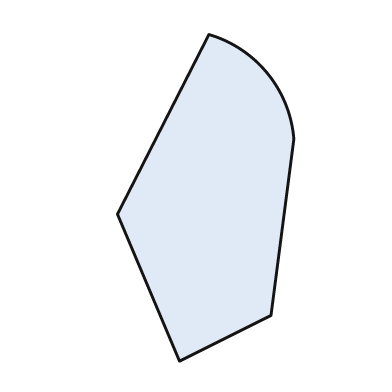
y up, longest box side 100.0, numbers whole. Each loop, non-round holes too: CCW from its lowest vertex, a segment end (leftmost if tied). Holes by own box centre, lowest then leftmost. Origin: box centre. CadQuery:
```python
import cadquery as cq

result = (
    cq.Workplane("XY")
    .moveTo(-8.0, -50.0)
    .lineTo(20.0, -36.0)
    .lineTo(27.0, 18.0)
    .threePointArc((19.0, 38.0), (1.0, 50.0))
    .lineTo(-27.0, -5.0)
    .close()
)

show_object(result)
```